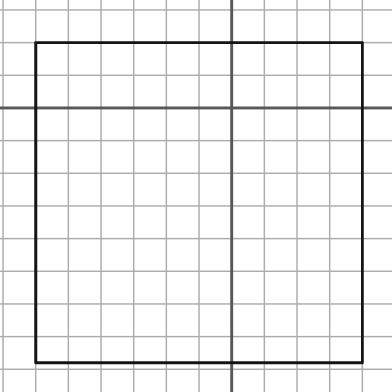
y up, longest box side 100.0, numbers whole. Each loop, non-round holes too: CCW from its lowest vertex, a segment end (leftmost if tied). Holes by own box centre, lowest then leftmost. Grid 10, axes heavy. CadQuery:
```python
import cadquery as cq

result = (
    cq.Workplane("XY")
    .moveTo(-60.0, -78.0)
    .lineTo(40.0, -78.0)
    .lineTo(40.0, 20.0)
    .lineTo(-60.0, 20.0)
    .close()
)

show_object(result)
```